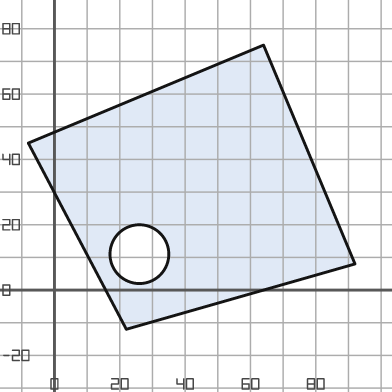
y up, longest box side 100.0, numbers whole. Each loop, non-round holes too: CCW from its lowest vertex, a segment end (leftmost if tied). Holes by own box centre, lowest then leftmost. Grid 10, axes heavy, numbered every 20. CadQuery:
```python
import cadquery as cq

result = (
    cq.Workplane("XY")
    .moveTo(22.0, -12.0)
    .lineTo(92.0, 8.0)
    .lineTo(64.0, 75.0)
    .lineTo(-8.0, 45.0)
    .close()
    .moveTo(26.0, 11.0)
    .circle(9.0)
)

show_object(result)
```